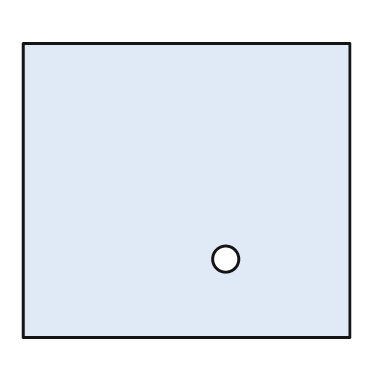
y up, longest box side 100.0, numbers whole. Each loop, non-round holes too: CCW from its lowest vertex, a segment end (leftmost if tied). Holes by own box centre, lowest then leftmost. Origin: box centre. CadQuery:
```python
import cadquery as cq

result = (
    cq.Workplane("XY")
    .moveTo(-50.0, -45.0)
    .lineTo(50.0, -45.0)
    .lineTo(50.0, 45.0)
    .lineTo(-50.0, 45.0)
    .close()
    .moveTo(12.0, -21.0)
    .circle(4.0)
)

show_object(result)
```